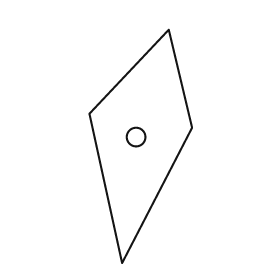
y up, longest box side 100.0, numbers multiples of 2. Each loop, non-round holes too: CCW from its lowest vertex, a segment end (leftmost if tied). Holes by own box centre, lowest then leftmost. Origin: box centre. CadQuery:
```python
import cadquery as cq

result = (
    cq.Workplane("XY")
    .moveTo(-8.0, -50.0)
    .lineTo(22.0, 8.0)
    .lineTo(12.0, 50.0)
    .lineTo(-22.0, 14.0)
    .close()
    .moveTo(-2.0, 4.0)
    .circle(4.0)
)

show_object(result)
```